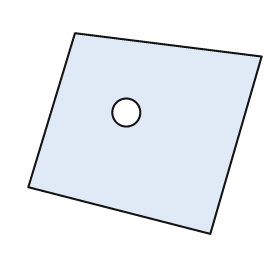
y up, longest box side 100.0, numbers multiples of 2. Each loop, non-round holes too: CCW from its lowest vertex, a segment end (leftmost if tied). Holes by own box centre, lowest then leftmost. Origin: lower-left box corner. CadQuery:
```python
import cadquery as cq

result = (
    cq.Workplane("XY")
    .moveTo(78.0, 0.0)
    .lineTo(100.0, 76.0)
    .lineTo(20.0, 86.0)
    .lineTo(0.0, 20.0)
    .close()
    .moveTo(42.0, 52.0)
    .circle(6.0)
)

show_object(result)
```